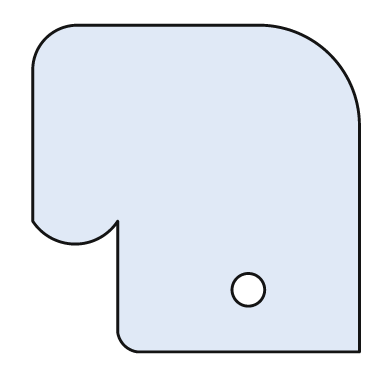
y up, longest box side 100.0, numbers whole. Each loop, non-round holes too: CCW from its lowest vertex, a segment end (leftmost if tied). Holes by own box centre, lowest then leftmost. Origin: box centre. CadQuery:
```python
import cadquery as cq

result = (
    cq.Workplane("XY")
    .moveTo(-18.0, -50.0)
    .lineTo(50.0, -50.0)
    .lineTo(50.0, 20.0)
    .threePointArc((41.0, 41.0), (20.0, 50.0))
    .lineTo(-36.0, 50.0)
    .threePointArc((-46.0, 46.0), (-50.0, 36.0))
    .lineTo(-50.0, -10.0)
    .threePointArc((-37.0, -17.0), (-24.0, -10.0))
    .lineTo(-24.0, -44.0)
    .threePointArc((-22.0, -48.0), (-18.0, -50.0))
    .close()
    .moveTo(16.0, -31.0)
    .circle(5.0)
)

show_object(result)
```